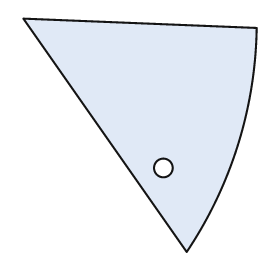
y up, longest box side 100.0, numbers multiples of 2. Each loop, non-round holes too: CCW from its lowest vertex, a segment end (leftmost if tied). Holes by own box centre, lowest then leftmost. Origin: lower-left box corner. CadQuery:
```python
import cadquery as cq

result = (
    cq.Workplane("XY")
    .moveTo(70.0, 0.0)
    .threePointArc((92.0, 46.0), (100.0, 96.0))
    .lineTo(0.0, 100.0)
    .close()
    .moveTo(60.0, 36.0)
    .circle(4.0)
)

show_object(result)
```